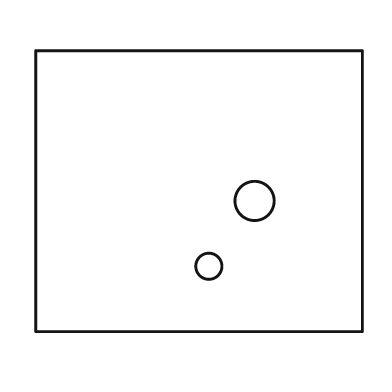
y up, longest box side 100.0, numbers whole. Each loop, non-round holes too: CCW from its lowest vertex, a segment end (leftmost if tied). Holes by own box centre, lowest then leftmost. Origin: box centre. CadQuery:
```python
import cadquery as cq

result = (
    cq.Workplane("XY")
    .moveTo(-50.0, -43.0)
    .lineTo(50.0, -43.0)
    .lineTo(50.0, 43.0)
    .lineTo(-50.0, 43.0)
    .close()
    .moveTo(3.0, -23.0)
    .circle(4.0)
    .moveTo(17.0, -3.0)
    .circle(6.0)
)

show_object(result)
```